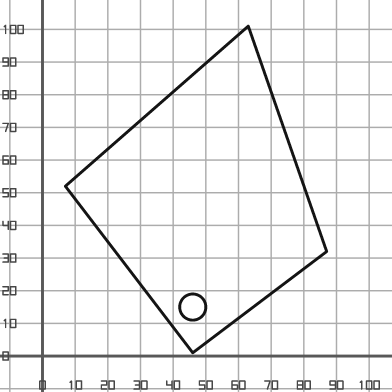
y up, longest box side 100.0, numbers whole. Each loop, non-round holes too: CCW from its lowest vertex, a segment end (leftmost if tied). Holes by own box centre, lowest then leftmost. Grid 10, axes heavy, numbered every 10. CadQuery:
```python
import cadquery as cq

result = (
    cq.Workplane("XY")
    .moveTo(46.0, 1.0)
    .lineTo(87.0, 32.0)
    .lineTo(63.0, 101.0)
    .lineTo(7.0, 52.0)
    .close()
    .moveTo(46.0, 15.0)
    .circle(4.0)
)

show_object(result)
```